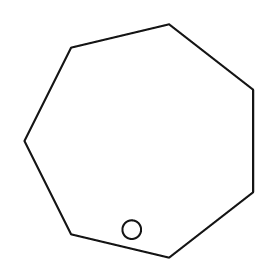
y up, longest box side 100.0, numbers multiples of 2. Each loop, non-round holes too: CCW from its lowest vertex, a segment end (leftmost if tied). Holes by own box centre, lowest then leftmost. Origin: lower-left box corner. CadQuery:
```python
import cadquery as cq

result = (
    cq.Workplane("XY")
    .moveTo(62.0, 0.0)
    .lineTo(98.0, 28.0)
    .lineTo(98.0, 72.0)
    .lineTo(62.0, 100.0)
    .lineTo(20.0, 90.0)
    .lineTo(0.0, 50.0)
    .lineTo(20.0, 10.0)
    .close()
    .moveTo(46.0, 12.0)
    .circle(4.0)
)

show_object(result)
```